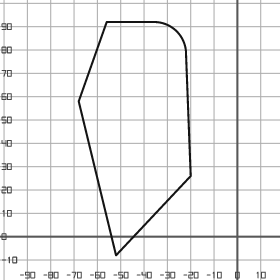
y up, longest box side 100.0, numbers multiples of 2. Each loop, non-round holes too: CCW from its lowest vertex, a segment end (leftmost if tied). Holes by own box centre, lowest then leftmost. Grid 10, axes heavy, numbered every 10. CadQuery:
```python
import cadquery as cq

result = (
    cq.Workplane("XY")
    .moveTo(-52.0, -8.0)
    .lineTo(-20.0, 26.0)
    .lineTo(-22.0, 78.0)
    .threePointArc((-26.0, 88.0), (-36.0, 92.0))
    .lineTo(-56.0, 92.0)
    .lineTo(-68.0, 58.0)
    .close()
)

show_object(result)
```